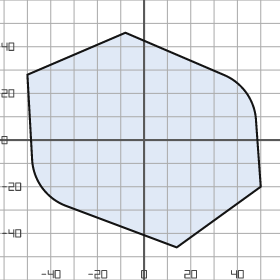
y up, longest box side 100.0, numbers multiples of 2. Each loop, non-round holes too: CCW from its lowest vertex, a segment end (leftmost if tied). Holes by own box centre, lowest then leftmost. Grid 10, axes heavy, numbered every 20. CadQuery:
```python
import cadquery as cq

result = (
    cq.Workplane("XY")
    .moveTo(14.0, -46.0)
    .lineTo(50.0, -20.0)
    .lineTo(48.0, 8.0)
    .threePointArc((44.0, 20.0), (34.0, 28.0))
    .lineTo(-8.0, 46.0)
    .lineTo(-50.0, 28.0)
    .lineTo(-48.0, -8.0)
    .threePointArc((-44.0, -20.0), (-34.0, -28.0))
    .close()
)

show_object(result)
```